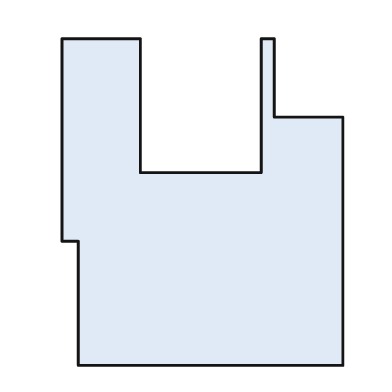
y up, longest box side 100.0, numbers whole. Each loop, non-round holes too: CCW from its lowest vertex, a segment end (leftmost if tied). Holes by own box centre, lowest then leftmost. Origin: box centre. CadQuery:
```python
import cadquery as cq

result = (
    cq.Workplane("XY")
    .moveTo(-38.0, -50.0)
    .lineTo(43.0, -50.0)
    .lineTo(43.0, 26.0)
    .lineTo(22.0, 26.0)
    .lineTo(22.0, 50.0)
    .lineTo(18.0, 50.0)
    .lineTo(18.0, 9.0)
    .lineTo(-19.0, 9.0)
    .lineTo(-19.0, 50.0)
    .lineTo(-43.0, 50.0)
    .lineTo(-43.0, -12.0)
    .lineTo(-38.0, -12.0)
    .close()
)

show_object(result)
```